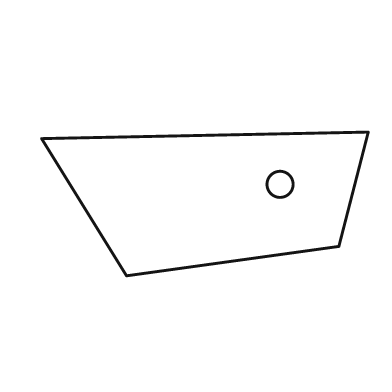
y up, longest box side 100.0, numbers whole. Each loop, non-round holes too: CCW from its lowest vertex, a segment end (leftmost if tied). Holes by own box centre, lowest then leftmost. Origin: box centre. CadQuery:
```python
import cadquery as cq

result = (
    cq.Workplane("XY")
    .moveTo(-24.0, -22.0)
    .lineTo(41.0, -13.0)
    .lineTo(50.0, 22.0)
    .lineTo(-50.0, 20.0)
    .close()
    .moveTo(23.0, 6.0)
    .circle(4.0)
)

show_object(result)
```